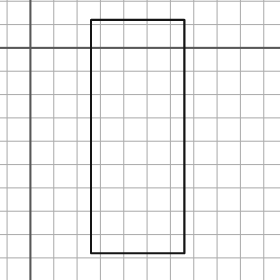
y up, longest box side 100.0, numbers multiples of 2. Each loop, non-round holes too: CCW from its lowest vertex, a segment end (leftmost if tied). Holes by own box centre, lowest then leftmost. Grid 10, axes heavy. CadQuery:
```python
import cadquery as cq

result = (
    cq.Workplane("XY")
    .moveTo(26.0, -88.0)
    .lineTo(66.0, -88.0)
    .lineTo(66.0, 12.0)
    .lineTo(26.0, 12.0)
    .close()
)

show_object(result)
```